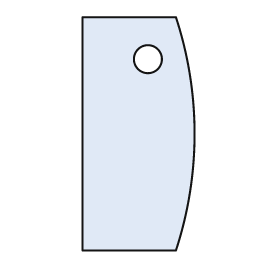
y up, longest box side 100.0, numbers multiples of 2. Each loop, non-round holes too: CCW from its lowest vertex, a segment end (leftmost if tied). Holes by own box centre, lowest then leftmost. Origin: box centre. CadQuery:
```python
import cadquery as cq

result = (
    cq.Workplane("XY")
    .moveTo(-24.0, -50.0)
    .lineTo(16.0, -50.0)
    .threePointArc((24.0, 0.0), (16.0, 50.0))
    .lineTo(-24.0, 50.0)
    .close()
    .moveTo(4.0, 32.0)
    .circle(6.0)
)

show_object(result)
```